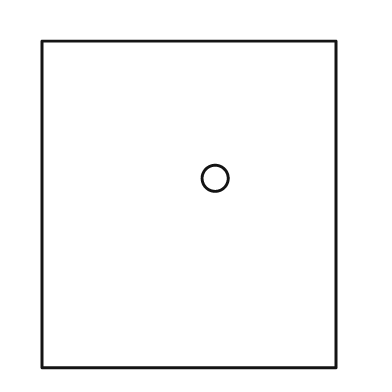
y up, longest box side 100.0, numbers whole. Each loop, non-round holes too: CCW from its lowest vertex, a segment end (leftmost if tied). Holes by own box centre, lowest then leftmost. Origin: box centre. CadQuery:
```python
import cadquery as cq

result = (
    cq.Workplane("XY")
    .moveTo(-45.0, -50.0)
    .lineTo(45.0, -50.0)
    .lineTo(45.0, 50.0)
    .lineTo(-45.0, 50.0)
    .close()
    .moveTo(8.0, 8.0)
    .circle(4.0)
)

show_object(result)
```